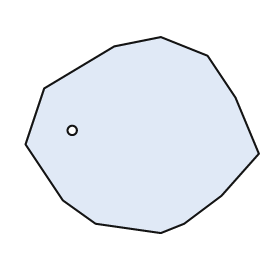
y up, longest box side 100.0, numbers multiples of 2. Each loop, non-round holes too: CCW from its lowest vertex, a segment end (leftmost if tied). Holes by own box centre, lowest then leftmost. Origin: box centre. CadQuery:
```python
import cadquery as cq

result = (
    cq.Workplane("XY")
    .moveTo(8.0, -42.0)
    .lineTo(18.0, -38.0)
    .lineTo(34.0, -26.0)
    .lineTo(50.0, -8.0)
    .lineTo(40.0, 16.0)
    .lineTo(28.0, 34.0)
    .lineTo(8.0, 42.0)
    .lineTo(-12.0, 38.0)
    .lineTo(-42.0, 20.0)
    .lineTo(-50.0, -4.0)
    .lineTo(-34.0, -28.0)
    .lineTo(-20.0, -38.0)
    .close()
    .moveTo(-30.0, 2.0)
    .circle(2.0)
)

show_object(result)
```